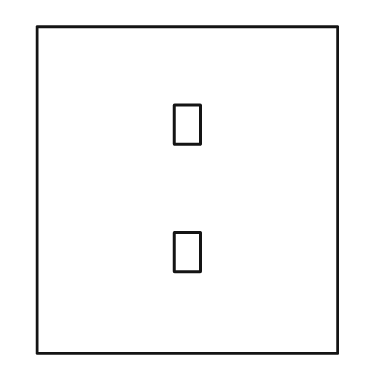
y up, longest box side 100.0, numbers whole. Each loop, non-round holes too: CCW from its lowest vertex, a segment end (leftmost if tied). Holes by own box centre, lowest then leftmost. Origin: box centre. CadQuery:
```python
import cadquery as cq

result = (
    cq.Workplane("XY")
    .moveTo(-46.0, -50.0)
    .lineTo(46.0, -50.0)
    .lineTo(46.0, 50.0)
    .lineTo(-46.0, 50.0)
    .close()
    .moveTo(-4.0, -25.0)
    .lineTo(4.0, -25.0)
    .lineTo(4.0, -13.0)
    .lineTo(-4.0, -13.0)
    .close()
    .moveTo(-4.0, 14.0)
    .lineTo(4.0, 14.0)
    .lineTo(4.0, 26.0)
    .lineTo(-4.0, 26.0)
    .close()
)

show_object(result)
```